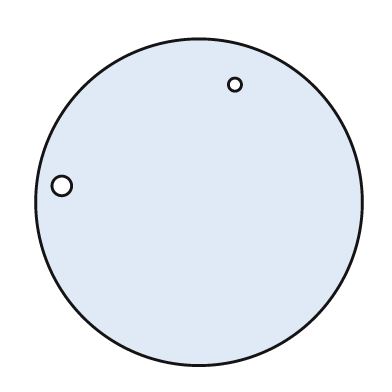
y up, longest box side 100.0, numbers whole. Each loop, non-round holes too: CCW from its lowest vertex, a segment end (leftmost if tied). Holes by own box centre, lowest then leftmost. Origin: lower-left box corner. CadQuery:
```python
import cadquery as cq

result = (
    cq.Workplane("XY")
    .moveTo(50.0, 50.0)
    .circle(50.0)
    .moveTo(8.0, 55.0)
    .circle(3.0)
    .moveTo(61.0, 86.0)
    .circle(2.0)
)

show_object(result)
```